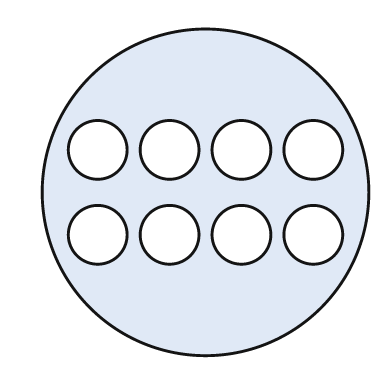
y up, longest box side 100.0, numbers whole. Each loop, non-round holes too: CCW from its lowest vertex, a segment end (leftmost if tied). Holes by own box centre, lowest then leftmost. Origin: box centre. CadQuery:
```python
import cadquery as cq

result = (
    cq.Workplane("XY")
    .moveTo(0.0, 0.0)
    .circle(50.0)
    .moveTo(-33.0, -13.0)
    .circle(9.0)
    .moveTo(-11.0, -13.0)
    .circle(9.0)
    .moveTo(11.0, -13.0)
    .circle(9.0)
    .moveTo(33.0, -13.0)
    .circle(9.0)
    .moveTo(-33.0, 13.0)
    .circle(9.0)
    .moveTo(-11.0, 13.0)
    .circle(9.0)
    .moveTo(11.0, 13.0)
    .circle(9.0)
    .moveTo(33.0, 13.0)
    .circle(9.0)
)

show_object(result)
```